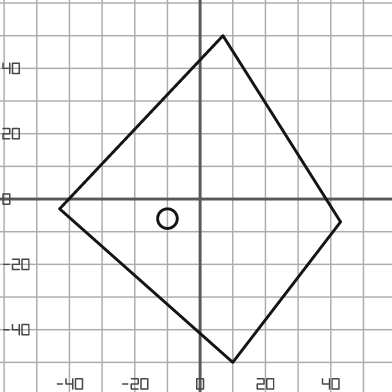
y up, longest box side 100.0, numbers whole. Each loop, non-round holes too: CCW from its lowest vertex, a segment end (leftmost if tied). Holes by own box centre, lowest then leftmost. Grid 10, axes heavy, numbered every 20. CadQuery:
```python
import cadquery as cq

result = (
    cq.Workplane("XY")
    .moveTo(10.0, -50.0)
    .lineTo(43.0, -7.0)
    .lineTo(7.0, 50.0)
    .lineTo(-43.0, -3.0)
    .close()
    .moveTo(-10.0, -6.0)
    .circle(3.0)
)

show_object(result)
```